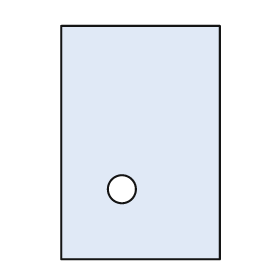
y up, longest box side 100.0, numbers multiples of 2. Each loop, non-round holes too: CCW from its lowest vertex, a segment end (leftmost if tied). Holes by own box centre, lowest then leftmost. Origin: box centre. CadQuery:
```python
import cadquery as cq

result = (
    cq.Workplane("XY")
    .moveTo(-34.0, -50.0)
    .lineTo(34.0, -50.0)
    .lineTo(34.0, 50.0)
    .lineTo(-34.0, 50.0)
    .close()
    .moveTo(-8.0, -20.0)
    .circle(6.0)
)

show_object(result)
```